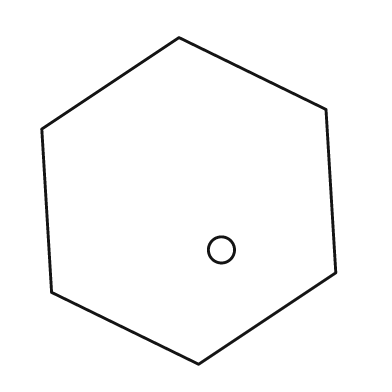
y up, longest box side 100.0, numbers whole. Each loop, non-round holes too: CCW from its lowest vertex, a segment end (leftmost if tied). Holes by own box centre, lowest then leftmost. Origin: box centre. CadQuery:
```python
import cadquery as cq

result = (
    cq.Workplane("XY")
    .moveTo(3.0, -50.0)
    .lineTo(45.0, -22.0)
    .lineTo(42.0, 28.0)
    .lineTo(-3.0, 50.0)
    .lineTo(-45.0, 22.0)
    .lineTo(-42.0, -28.0)
    .close()
    .moveTo(10.0, -15.0)
    .circle(4.0)
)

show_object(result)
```